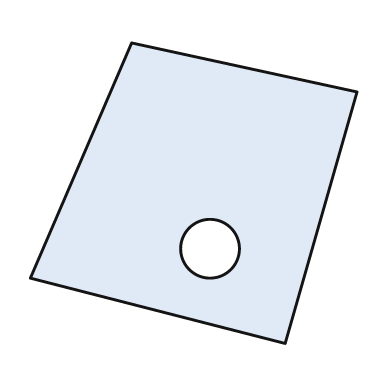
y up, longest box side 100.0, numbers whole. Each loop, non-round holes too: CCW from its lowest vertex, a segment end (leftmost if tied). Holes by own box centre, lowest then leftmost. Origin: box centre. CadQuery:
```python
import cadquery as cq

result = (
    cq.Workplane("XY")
    .moveTo(28.0, -46.0)
    .lineTo(50.0, 31.0)
    .lineTo(-19.0, 46.0)
    .lineTo(-50.0, -26.0)
    .close()
    .moveTo(5.0, -17.0)
    .circle(9.0)
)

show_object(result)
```